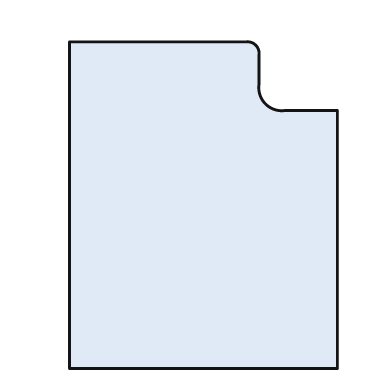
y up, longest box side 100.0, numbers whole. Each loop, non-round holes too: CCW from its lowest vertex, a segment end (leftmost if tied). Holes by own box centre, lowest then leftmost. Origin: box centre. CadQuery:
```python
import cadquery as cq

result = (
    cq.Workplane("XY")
    .moveTo(-41.0, -50.0)
    .lineTo(41.0, -50.0)
    .lineTo(41.0, 29.0)
    .lineTo(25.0, 29.0)
    .threePointArc((19.0, 31.0), (17.0, 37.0))
    .lineTo(17.0, 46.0)
    .threePointArc((16.0, 49.0), (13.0, 50.0))
    .lineTo(-41.0, 50.0)
    .close()
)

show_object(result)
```